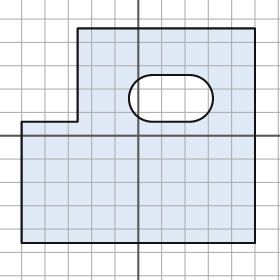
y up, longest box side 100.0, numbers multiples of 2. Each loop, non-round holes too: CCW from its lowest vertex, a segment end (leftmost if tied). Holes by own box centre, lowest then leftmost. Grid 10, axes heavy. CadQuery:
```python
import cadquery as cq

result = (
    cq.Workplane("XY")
    .moveTo(-50.0, -46.0)
    .lineTo(50.0, -46.0)
    .lineTo(50.0, 46.0)
    .lineTo(-26.0, 46.0)
    .lineTo(-26.0, 6.0)
    .lineTo(-50.0, 6.0)
    .close()
    .moveTo(6.0, 6.0)
    .lineTo(22.0, 6.0)
    .threePointArc((32.0, 16.0), (22.0, 26.0))
    .lineTo(6.0, 26.0)
    .threePointArc((-4.0, 16.0), (6.0, 6.0))
    .close()
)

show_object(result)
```